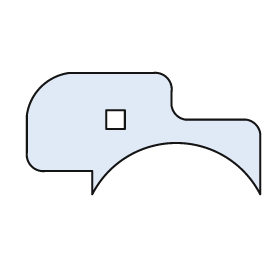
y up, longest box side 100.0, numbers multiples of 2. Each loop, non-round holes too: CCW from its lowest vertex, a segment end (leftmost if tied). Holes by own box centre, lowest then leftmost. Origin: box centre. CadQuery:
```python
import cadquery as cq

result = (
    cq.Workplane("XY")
    .moveTo(-22.0, -26.0)
    .threePointArc((14.0, -4.0), (50.0, -26.0))
    .lineTo(50.0, 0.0)
    .threePointArc((48.0, 4.0), (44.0, 6.0))
    .lineTo(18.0, 6.0)
    .threePointArc((14.0, 8.0), (12.0, 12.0))
    .lineTo(12.0, 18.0)
    .threePointArc((10.0, 24.0), (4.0, 26.0))
    .lineTo(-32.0, 26.0)
    .threePointArc((-44.0, 20.0), (-50.0, 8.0))
    .lineTo(-50.0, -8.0)
    .threePointArc((-48.0, -14.0), (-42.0, -16.0))
    .lineTo(-22.0, -16.0)
    .close()
    .moveTo(-16.0, 2.0)
    .lineTo(-8.0, 2.0)
    .lineTo(-8.0, 10.0)
    .lineTo(-16.0, 10.0)
    .close()
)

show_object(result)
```